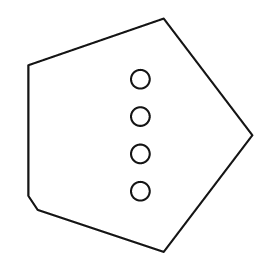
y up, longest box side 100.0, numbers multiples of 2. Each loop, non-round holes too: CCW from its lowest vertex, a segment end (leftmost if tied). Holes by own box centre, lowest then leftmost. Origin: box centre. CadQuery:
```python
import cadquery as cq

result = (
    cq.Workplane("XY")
    .moveTo(10.0, -50.0)
    .lineTo(48.0, 0.0)
    .lineTo(10.0, 50.0)
    .lineTo(-48.0, 30.0)
    .lineTo(-48.0, -26.0)
    .lineTo(-44.0, -32.0)
    .close()
    .moveTo(0.0, -24.0)
    .circle(4.0)
    .moveTo(0.0, -8.0)
    .circle(4.0)
    .moveTo(0.0, 8.0)
    .circle(4.0)
    .moveTo(0.0, 24.0)
    .circle(4.0)
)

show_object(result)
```